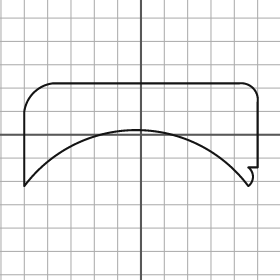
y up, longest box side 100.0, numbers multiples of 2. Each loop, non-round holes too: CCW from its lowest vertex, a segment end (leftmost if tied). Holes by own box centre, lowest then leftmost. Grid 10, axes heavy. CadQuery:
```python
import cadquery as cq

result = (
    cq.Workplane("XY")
    .moveTo(-50.0, -22.0)
    .threePointArc((-2.0, 2.0), (46.0, -22.0))
    .threePointArc((48.0, -18.0), (46.0, -14.0))
    .lineTo(50.0, -14.0)
    .lineTo(50.0, 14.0)
    .threePointArc((48.0, 20.0), (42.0, 22.0))
    .lineTo(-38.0, 22.0)
    .threePointArc((-46.0, 18.0), (-50.0, 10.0))
    .close()
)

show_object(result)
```